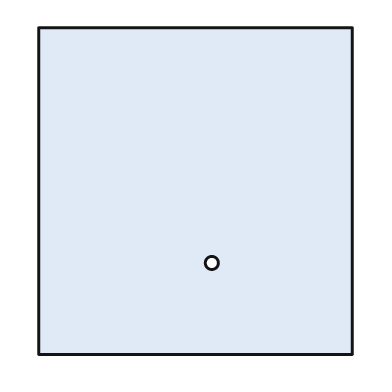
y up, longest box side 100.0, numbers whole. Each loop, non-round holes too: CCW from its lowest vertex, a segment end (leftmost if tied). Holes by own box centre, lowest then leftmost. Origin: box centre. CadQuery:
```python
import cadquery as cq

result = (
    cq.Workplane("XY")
    .moveTo(-48.0, -50.0)
    .lineTo(48.0, -50.0)
    .lineTo(48.0, 50.0)
    .lineTo(-48.0, 50.0)
    .close()
    .moveTo(5.0, -22.0)
    .circle(2.0)
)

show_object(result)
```